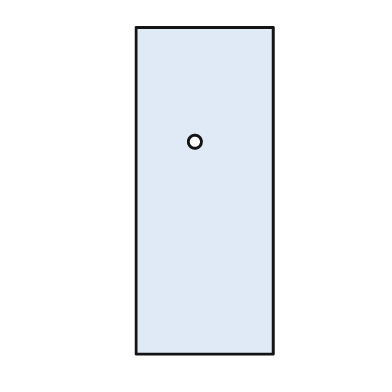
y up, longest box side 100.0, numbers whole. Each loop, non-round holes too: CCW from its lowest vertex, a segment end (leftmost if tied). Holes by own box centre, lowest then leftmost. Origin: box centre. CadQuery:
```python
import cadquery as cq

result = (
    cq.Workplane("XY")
    .moveTo(-21.0, -50.0)
    .lineTo(21.0, -50.0)
    .lineTo(21.0, 50.0)
    .lineTo(-21.0, 50.0)
    .close()
    .moveTo(-3.0, 15.0)
    .circle(2.0)
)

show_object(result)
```